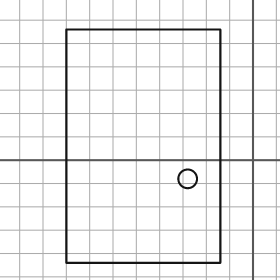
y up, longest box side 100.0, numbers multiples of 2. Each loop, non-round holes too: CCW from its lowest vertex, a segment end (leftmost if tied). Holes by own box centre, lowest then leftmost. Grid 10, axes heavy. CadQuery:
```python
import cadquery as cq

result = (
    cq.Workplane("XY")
    .moveTo(-80.0, -44.0)
    .lineTo(-14.0, -44.0)
    .lineTo(-14.0, 56.0)
    .lineTo(-80.0, 56.0)
    .close()
    .moveTo(-28.0, -8.0)
    .circle(4.0)
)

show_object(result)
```